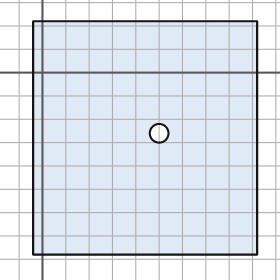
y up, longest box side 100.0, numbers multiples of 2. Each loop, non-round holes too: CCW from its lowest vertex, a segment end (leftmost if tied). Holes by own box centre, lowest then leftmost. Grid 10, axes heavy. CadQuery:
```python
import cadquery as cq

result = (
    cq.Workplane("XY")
    .moveTo(-4.0, -78.0)
    .lineTo(92.0, -78.0)
    .lineTo(92.0, 22.0)
    .lineTo(-4.0, 22.0)
    .close()
    .moveTo(50.0, -26.0)
    .circle(4.0)
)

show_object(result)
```